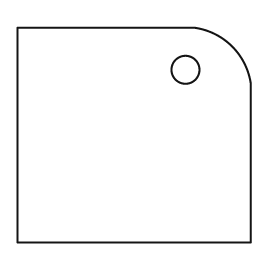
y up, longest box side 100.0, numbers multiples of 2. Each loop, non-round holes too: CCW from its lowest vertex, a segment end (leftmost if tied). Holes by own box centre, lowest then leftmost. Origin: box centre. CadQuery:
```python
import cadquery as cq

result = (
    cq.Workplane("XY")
    .moveTo(-50.0, -46.0)
    .lineTo(50.0, -46.0)
    .lineTo(50.0, 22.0)
    .threePointArc((42.0, 38.0), (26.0, 46.0))
    .lineTo(-50.0, 46.0)
    .close()
    .moveTo(22.0, 28.0)
    .circle(6.0)
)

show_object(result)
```